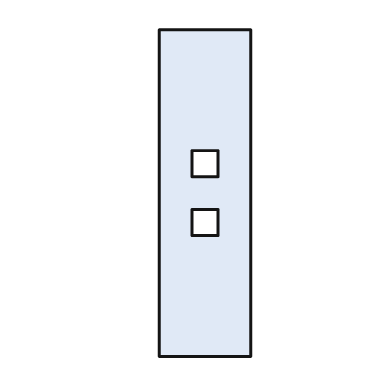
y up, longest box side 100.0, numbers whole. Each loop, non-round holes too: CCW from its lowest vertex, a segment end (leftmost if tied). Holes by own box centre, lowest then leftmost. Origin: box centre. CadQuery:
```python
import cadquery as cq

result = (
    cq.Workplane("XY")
    .moveTo(-14.0, -50.0)
    .lineTo(14.0, -50.0)
    .lineTo(14.0, 50.0)
    .lineTo(-14.0, 50.0)
    .close()
    .moveTo(-4.0, -13.0)
    .lineTo(4.0, -13.0)
    .lineTo(4.0, -5.0)
    .lineTo(-4.0, -5.0)
    .close()
    .moveTo(-4.0, 5.0)
    .lineTo(4.0, 5.0)
    .lineTo(4.0, 13.0)
    .lineTo(-4.0, 13.0)
    .close()
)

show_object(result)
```